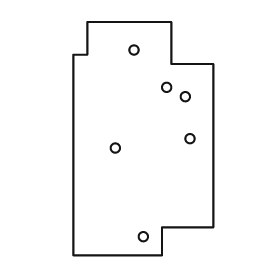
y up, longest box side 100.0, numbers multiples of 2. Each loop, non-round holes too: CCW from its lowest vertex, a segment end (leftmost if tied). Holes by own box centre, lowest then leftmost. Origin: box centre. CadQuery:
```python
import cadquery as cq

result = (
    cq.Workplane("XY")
    .moveTo(-30.0, -50.0)
    .lineTo(8.0, -50.0)
    .lineTo(8.0, -38.0)
    .lineTo(30.0, -38.0)
    .lineTo(30.0, 32.0)
    .lineTo(12.0, 32.0)
    .lineTo(12.0, 50.0)
    .lineTo(-24.0, 50.0)
    .lineTo(-24.0, 36.0)
    .lineTo(-30.0, 36.0)
    .close()
    .moveTo(0.0, -42.0)
    .circle(2.0)
    .moveTo(-12.0, -4.0)
    .circle(2.0)
    .moveTo(20.0, 0.0)
    .circle(2.0)
    .moveTo(18.0, 18.0)
    .circle(2.0)
    .moveTo(10.0, 22.0)
    .circle(2.0)
    .moveTo(-4.0, 38.0)
    .circle(2.0)
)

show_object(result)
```